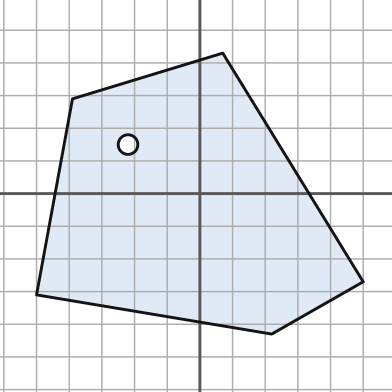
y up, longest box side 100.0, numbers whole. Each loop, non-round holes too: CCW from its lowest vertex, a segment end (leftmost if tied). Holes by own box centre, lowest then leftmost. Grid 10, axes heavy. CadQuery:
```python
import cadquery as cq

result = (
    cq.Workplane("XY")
    .moveTo(22.0, -43.0)
    .lineTo(50.0, -27.0)
    .lineTo(7.0, 43.0)
    .lineTo(-39.0, 29.0)
    .lineTo(-50.0, -31.0)
    .close()
    .moveTo(-22.0, 15.0)
    .circle(3.0)
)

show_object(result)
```